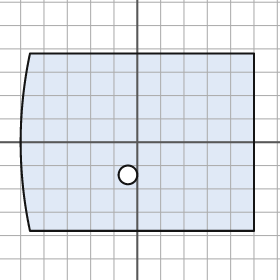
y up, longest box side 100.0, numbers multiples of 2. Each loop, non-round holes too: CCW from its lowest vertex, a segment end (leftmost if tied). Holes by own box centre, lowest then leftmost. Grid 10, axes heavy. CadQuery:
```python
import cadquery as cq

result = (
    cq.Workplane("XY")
    .moveTo(-46.0, -38.0)
    .lineTo(50.0, -38.0)
    .lineTo(50.0, 38.0)
    .lineTo(-46.0, 38.0)
    .threePointArc((-50.0, 0.0), (-46.0, -38.0))
    .close()
    .moveTo(-4.0, -14.0)
    .circle(4.0)
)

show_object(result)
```